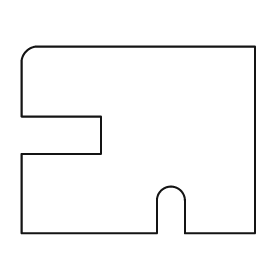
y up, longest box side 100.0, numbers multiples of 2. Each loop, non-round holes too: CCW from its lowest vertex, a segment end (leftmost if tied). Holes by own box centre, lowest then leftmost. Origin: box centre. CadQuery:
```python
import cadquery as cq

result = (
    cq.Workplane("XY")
    .moveTo(-50.0, -40.0)
    .lineTo(8.0, -40.0)
    .lineTo(8.0, -26.0)
    .threePointArc((14.0, -20.0), (20.0, -26.0))
    .lineTo(20.0, -40.0)
    .lineTo(50.0, -40.0)
    .lineTo(50.0, 40.0)
    .lineTo(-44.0, 40.0)
    .threePointArc((-48.0, 38.0), (-50.0, 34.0))
    .lineTo(-50.0, 10.0)
    .lineTo(-16.0, 10.0)
    .lineTo(-16.0, -6.0)
    .lineTo(-50.0, -6.0)
    .close()
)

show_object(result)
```